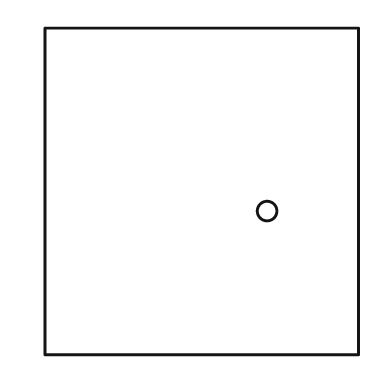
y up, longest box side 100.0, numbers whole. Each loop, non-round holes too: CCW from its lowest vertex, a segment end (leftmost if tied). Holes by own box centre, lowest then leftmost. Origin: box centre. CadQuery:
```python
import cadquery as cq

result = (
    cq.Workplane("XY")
    .moveTo(-48.0, -50.0)
    .lineTo(48.0, -50.0)
    .lineTo(48.0, 50.0)
    .lineTo(-48.0, 50.0)
    .close()
    .moveTo(20.0, -6.0)
    .circle(3.0)
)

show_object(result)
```